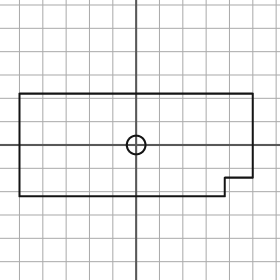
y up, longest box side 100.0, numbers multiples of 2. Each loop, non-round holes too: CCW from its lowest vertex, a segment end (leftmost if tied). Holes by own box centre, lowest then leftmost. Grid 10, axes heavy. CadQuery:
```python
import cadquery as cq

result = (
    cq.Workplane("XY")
    .moveTo(-50.0, -22.0)
    .lineTo(38.0, -22.0)
    .lineTo(38.0, -14.0)
    .lineTo(50.0, -14.0)
    .lineTo(50.0, 22.0)
    .lineTo(-50.0, 22.0)
    .close()
    .moveTo(0.0, 0.0)
    .circle(4.0)
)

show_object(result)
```